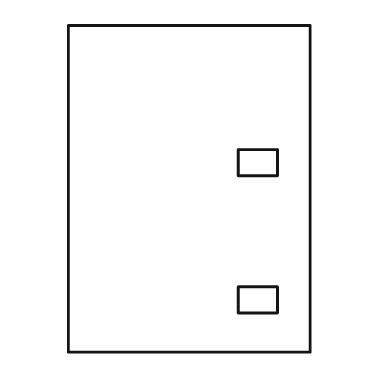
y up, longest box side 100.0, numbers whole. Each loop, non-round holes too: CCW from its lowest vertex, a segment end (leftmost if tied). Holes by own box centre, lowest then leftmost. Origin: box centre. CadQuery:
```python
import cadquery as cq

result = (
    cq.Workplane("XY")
    .moveTo(-37.0, -50.0)
    .lineTo(37.0, -50.0)
    .lineTo(37.0, 50.0)
    .lineTo(-37.0, 50.0)
    .close()
    .moveTo(15.0, -38.0)
    .lineTo(27.0, -38.0)
    .lineTo(27.0, -30.0)
    .lineTo(15.0, -30.0)
    .close()
    .moveTo(15.0, 4.0)
    .lineTo(27.0, 4.0)
    .lineTo(27.0, 12.0)
    .lineTo(15.0, 12.0)
    .close()
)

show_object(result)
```